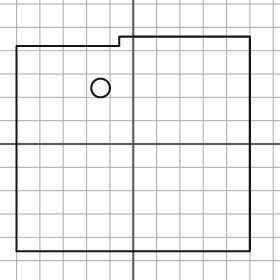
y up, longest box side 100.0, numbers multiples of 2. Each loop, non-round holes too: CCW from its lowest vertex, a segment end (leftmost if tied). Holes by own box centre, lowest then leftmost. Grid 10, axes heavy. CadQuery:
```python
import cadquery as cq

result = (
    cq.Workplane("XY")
    .moveTo(-50.0, -46.0)
    .lineTo(50.0, -46.0)
    .lineTo(50.0, 46.0)
    .lineTo(-6.0, 46.0)
    .lineTo(-6.0, 42.0)
    .lineTo(-50.0, 42.0)
    .close()
    .moveTo(-14.0, 24.0)
    .circle(4.0)
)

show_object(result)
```